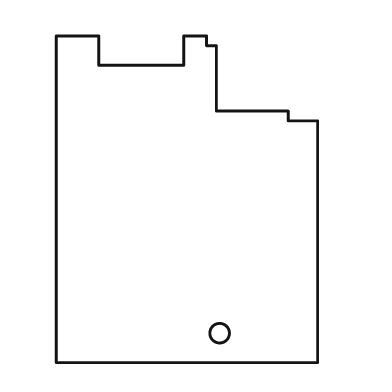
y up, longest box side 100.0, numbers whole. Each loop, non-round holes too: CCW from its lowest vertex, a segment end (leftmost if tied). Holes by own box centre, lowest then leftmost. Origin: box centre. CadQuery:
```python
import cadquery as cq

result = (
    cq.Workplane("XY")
    .moveTo(-40.0, -50.0)
    .lineTo(40.0, -50.0)
    .lineTo(40.0, 24.0)
    .lineTo(31.0, 24.0)
    .lineTo(31.0, 27.0)
    .lineTo(9.0, 27.0)
    .lineTo(9.0, 47.0)
    .lineTo(6.0, 47.0)
    .lineTo(6.0, 50.0)
    .lineTo(-1.0, 50.0)
    .lineTo(-1.0, 41.0)
    .lineTo(-27.0, 41.0)
    .lineTo(-27.0, 50.0)
    .lineTo(-40.0, 50.0)
    .close()
    .moveTo(10.0, -41.0)
    .circle(3.0)
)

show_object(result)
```